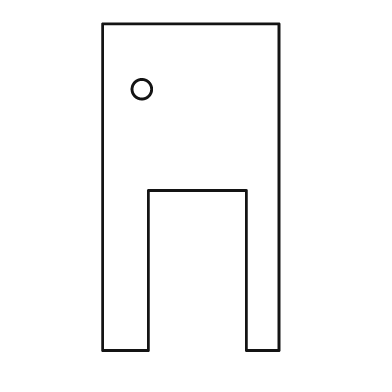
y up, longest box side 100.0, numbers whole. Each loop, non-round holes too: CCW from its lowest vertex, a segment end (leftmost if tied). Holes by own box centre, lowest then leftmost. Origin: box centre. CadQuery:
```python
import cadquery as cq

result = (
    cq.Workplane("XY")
    .moveTo(-27.0, -50.0)
    .lineTo(-13.0, -50.0)
    .lineTo(-13.0, -1.0)
    .lineTo(17.0, -1.0)
    .lineTo(17.0, -50.0)
    .lineTo(27.0, -50.0)
    .lineTo(27.0, 50.0)
    .lineTo(-27.0, 50.0)
    .close()
    .moveTo(-15.0, 30.0)
    .circle(3.0)
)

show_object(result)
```